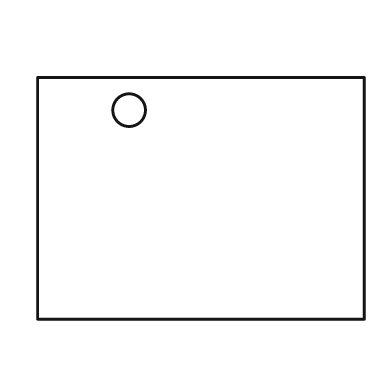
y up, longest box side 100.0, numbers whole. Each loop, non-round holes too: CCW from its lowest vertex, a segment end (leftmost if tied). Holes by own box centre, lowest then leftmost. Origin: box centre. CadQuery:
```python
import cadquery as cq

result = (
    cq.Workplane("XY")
    .moveTo(-50.0, -37.0)
    .lineTo(50.0, -37.0)
    .lineTo(50.0, 37.0)
    .lineTo(-50.0, 37.0)
    .close()
    .moveTo(-22.0, 27.0)
    .circle(5.0)
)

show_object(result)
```